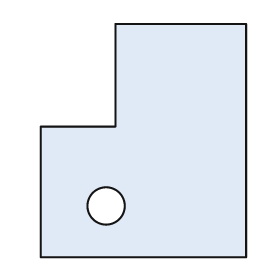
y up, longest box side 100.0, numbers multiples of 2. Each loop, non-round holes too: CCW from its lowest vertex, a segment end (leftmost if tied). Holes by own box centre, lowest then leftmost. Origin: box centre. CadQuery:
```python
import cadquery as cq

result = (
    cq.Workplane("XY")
    .moveTo(-44.0, -50.0)
    .lineTo(44.0, -50.0)
    .lineTo(44.0, 50.0)
    .lineTo(-12.0, 50.0)
    .lineTo(-12.0, 6.0)
    .lineTo(-44.0, 6.0)
    .close()
    .moveTo(-16.0, -28.0)
    .circle(8.0)
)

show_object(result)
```